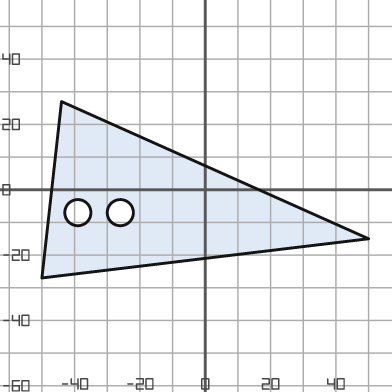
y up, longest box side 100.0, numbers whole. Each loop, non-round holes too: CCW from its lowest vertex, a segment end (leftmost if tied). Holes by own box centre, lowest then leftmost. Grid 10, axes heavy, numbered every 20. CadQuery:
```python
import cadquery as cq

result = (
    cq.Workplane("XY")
    .moveTo(-50.0, -27.0)
    .lineTo(50.0, -15.0)
    .lineTo(-44.0, 27.0)
    .close()
    .moveTo(-39.0, -7.0)
    .circle(4.0)
    .moveTo(-26.0, -7.0)
    .circle(4.0)
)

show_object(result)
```